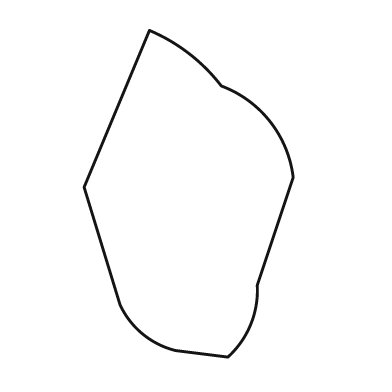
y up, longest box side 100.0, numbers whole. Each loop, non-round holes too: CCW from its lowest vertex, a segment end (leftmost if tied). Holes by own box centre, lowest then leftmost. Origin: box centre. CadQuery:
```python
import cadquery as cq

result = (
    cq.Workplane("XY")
    .moveTo(12.0, -50.0)
    .threePointArc((19.0, -40.0), (21.0, -28.0))
    .lineTo(32.0, 5.0)
    .threePointArc((25.0, 22.0), (10.0, 33.0))
    .threePointArc((0.0, 43.0), (-12.0, 50.0))
    .lineTo(-32.0, 2.0)
    .lineTo(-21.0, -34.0)
    .threePointArc((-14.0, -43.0), (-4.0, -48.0))
    .close()
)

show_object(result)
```